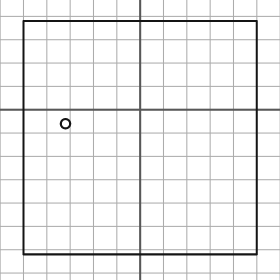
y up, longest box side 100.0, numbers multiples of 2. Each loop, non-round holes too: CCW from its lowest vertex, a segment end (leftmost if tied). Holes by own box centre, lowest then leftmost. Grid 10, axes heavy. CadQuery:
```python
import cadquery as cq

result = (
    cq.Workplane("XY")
    .moveTo(-50.0, -62.0)
    .lineTo(50.0, -62.0)
    .lineTo(50.0, 38.0)
    .lineTo(-50.0, 38.0)
    .close()
    .moveTo(-32.0, -6.0)
    .circle(2.0)
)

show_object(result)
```